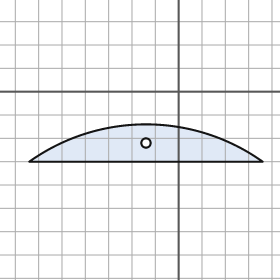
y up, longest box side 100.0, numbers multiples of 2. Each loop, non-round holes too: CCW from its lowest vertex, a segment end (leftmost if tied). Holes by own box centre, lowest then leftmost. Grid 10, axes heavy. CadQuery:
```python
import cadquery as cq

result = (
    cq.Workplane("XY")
    .moveTo(-64.0, -30.0)
    .lineTo(36.0, -30.0)
    .threePointArc((-14.0, -14.0), (-64.0, -30.0))
    .close()
    .moveTo(-14.0, -22.0)
    .circle(2.0)
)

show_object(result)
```